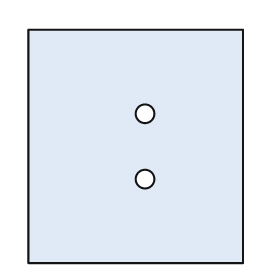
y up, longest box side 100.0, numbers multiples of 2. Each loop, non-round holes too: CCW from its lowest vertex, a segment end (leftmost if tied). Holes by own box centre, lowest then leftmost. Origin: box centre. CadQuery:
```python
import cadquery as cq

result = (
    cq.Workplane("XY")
    .moveTo(-46.0, -50.0)
    .lineTo(46.0, -50.0)
    .lineTo(46.0, 50.0)
    .lineTo(-46.0, 50.0)
    .close()
    .moveTo(4.0, -14.0)
    .circle(4.0)
    .moveTo(4.0, 14.0)
    .circle(4.0)
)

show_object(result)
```